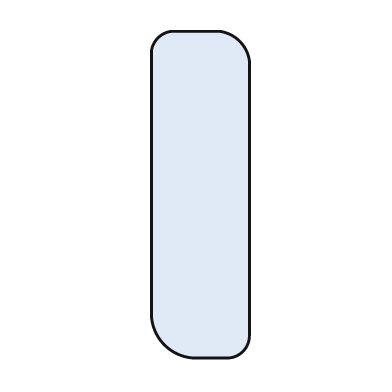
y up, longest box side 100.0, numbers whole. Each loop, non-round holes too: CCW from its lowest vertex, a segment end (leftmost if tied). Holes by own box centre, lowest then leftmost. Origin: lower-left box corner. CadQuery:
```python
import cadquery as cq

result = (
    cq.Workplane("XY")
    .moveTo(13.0, 0.0)
    .lineTo(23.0, 0.0)
    .threePointArc((28.0, 2.0), (30.0, 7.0))
    .lineTo(30.0, 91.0)
    .threePointArc((27.0, 97.0), (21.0, 100.0))
    .lineTo(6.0, 100.0)
    .threePointArc((2.0, 98.0), (0.0, 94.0))
    .lineTo(0.0, 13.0)
    .threePointArc((4.0, 4.0), (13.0, 0.0))
    .close()
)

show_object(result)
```